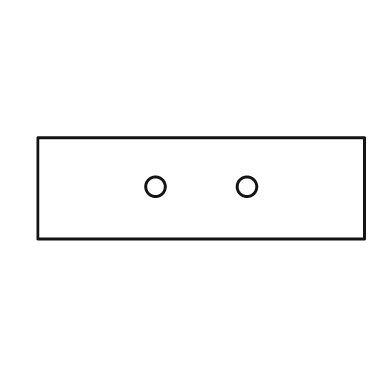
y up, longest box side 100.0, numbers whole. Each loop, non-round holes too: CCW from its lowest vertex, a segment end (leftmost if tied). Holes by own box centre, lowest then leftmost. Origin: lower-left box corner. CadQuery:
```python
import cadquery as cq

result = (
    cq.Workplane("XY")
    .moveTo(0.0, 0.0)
    .lineTo(100.0, 0.0)
    .lineTo(100.0, 31.0)
    .lineTo(0.0, 31.0)
    .close()
    .moveTo(36.0, 16.0)
    .circle(3.0)
    .moveTo(64.0, 16.0)
    .circle(3.0)
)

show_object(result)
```